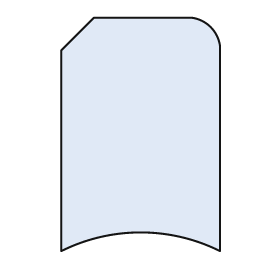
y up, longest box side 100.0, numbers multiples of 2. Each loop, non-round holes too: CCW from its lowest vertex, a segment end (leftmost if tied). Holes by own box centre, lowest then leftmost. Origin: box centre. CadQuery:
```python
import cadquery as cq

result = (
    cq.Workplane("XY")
    .moveTo(-34.0, -50.0)
    .threePointArc((0.0, -42.0), (34.0, -50.0))
    .lineTo(34.0, 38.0)
    .threePointArc((30.0, 46.0), (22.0, 50.0))
    .lineTo(-20.0, 50.0)
    .lineTo(-34.0, 36.0)
    .close()
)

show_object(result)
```